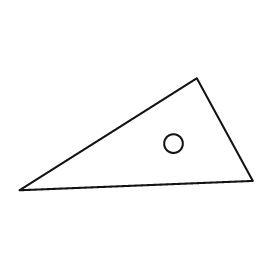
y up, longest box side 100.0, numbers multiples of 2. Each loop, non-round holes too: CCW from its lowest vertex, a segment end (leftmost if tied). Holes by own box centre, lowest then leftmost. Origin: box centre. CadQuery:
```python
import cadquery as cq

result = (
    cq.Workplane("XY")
    .moveTo(-50.0, -24.0)
    .lineTo(50.0, -20.0)
    .lineTo(26.0, 24.0)
    .close()
    .moveTo(16.0, -4.0)
    .circle(4.0)
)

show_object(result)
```